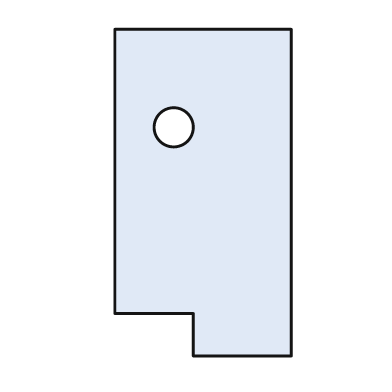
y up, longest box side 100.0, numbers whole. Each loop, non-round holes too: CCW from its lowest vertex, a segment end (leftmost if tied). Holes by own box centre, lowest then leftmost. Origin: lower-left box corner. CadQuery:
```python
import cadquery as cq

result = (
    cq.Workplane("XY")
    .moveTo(24.0, 0.0)
    .lineTo(54.0, 0.0)
    .lineTo(54.0, 100.0)
    .lineTo(0.0, 100.0)
    .lineTo(0.0, 13.0)
    .lineTo(24.0, 13.0)
    .close()
    .moveTo(18.0, 70.0)
    .circle(6.0)
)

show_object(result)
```